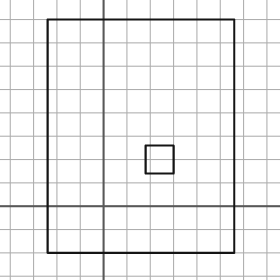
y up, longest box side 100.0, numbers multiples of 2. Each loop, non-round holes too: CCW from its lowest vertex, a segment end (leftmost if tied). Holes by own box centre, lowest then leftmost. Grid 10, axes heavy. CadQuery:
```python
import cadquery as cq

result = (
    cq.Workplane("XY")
    .moveTo(-24.0, -20.0)
    .lineTo(56.0, -20.0)
    .lineTo(56.0, 80.0)
    .lineTo(-24.0, 80.0)
    .close()
    .moveTo(18.0, 14.0)
    .lineTo(30.0, 14.0)
    .lineTo(30.0, 26.0)
    .lineTo(18.0, 26.0)
    .close()
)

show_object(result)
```